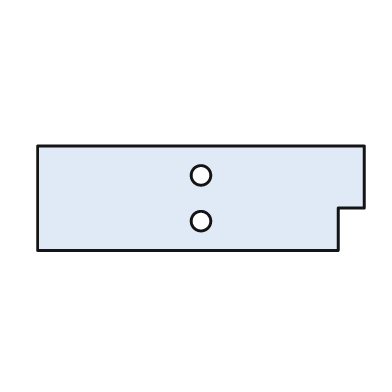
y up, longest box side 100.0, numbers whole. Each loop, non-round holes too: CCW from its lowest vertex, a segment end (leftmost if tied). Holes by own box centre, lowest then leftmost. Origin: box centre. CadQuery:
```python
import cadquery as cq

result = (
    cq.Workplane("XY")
    .moveTo(-50.0, -16.0)
    .lineTo(42.0, -16.0)
    .lineTo(42.0, -3.0)
    .lineTo(50.0, -3.0)
    .lineTo(50.0, 16.0)
    .lineTo(-50.0, 16.0)
    .close()
    .moveTo(0.0, -7.0)
    .circle(3.0)
    .moveTo(0.0, 7.0)
    .circle(3.0)
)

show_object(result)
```